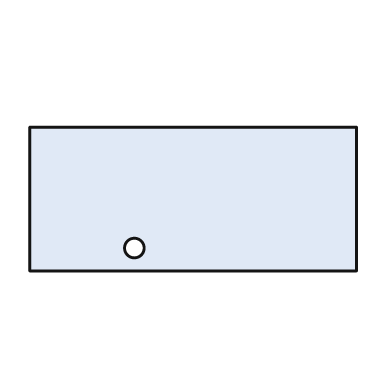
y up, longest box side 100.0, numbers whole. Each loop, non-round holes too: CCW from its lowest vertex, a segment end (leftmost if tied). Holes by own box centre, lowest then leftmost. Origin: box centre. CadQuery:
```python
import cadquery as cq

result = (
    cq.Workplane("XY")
    .moveTo(-50.0, -22.0)
    .lineTo(50.0, -22.0)
    .lineTo(50.0, 22.0)
    .lineTo(-50.0, 22.0)
    .close()
    .moveTo(-18.0, -15.0)
    .circle(3.0)
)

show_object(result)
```